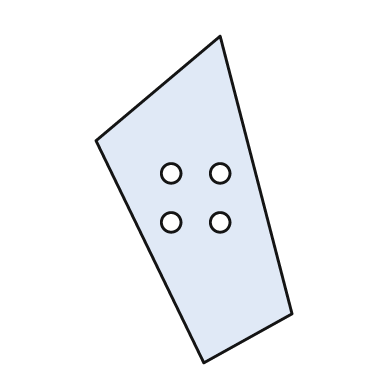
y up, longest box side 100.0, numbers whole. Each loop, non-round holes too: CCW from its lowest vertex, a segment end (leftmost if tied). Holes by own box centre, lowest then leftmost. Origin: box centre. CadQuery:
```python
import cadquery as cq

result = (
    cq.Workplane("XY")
    .moveTo(3.0, -50.0)
    .lineTo(30.0, -35.0)
    .lineTo(8.0, 50.0)
    .lineTo(-30.0, 18.0)
    .close()
    .moveTo(-7.0, -7.0)
    .circle(3.0)
    .moveTo(8.0, -7.0)
    .circle(3.0)
    .moveTo(-7.0, 8.0)
    .circle(3.0)
    .moveTo(8.0, 8.0)
    .circle(3.0)
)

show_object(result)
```